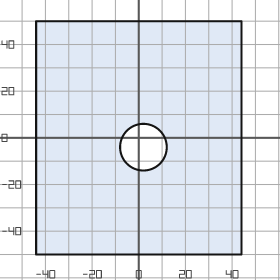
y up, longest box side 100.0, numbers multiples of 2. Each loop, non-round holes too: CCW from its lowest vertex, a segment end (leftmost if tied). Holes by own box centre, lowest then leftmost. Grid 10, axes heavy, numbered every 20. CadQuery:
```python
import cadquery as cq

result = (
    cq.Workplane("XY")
    .moveTo(-44.0, -50.0)
    .lineTo(44.0, -50.0)
    .lineTo(44.0, 50.0)
    .lineTo(-44.0, 50.0)
    .close()
    .moveTo(2.0, -4.0)
    .circle(10.0)
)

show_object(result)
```